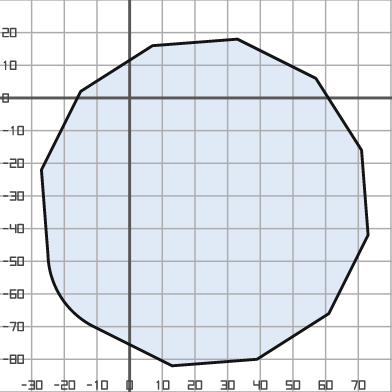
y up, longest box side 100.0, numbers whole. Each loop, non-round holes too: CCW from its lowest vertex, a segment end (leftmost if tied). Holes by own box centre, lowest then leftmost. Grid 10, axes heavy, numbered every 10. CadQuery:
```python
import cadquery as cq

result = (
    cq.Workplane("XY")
    .moveTo(13.0, -82.0)
    .lineTo(39.0, -80.0)
    .lineTo(61.0, -66.0)
    .lineTo(73.0, -42.0)
    .lineTo(71.0, -16.0)
    .lineTo(57.0, 6.0)
    .lineTo(33.0, 18.0)
    .lineTo(7.0, 16.0)
    .lineTo(-15.0, 2.0)
    .lineTo(-27.0, -22.0)
    .lineTo(-25.0, -48.0)
    .threePointArc((-21.0, -61.0), (-11.0, -70.0))
    .close()
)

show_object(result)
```